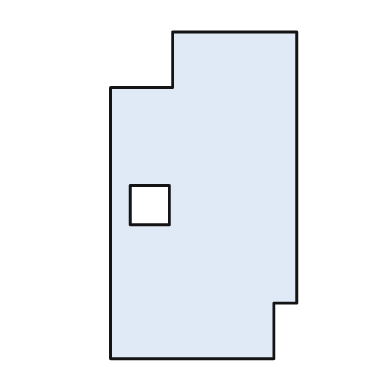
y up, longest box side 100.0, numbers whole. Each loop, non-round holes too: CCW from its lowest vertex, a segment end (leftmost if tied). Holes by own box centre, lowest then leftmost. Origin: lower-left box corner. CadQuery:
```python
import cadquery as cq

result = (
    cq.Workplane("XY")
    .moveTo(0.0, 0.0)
    .lineTo(50.0, 0.0)
    .lineTo(50.0, 17.0)
    .lineTo(57.0, 17.0)
    .lineTo(57.0, 100.0)
    .lineTo(19.0, 100.0)
    .lineTo(19.0, 83.0)
    .lineTo(0.0, 83.0)
    .close()
    .moveTo(6.0, 41.0)
    .lineTo(18.0, 41.0)
    .lineTo(18.0, 53.0)
    .lineTo(6.0, 53.0)
    .close()
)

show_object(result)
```